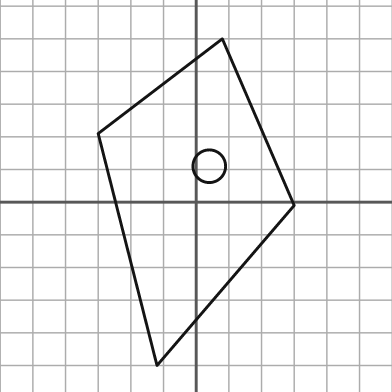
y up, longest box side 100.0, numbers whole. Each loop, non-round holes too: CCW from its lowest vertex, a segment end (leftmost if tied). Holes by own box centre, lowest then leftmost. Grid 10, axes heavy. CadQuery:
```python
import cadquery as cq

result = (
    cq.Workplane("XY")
    .moveTo(-12.0, -50.0)
    .lineTo(30.0, -1.0)
    .lineTo(8.0, 50.0)
    .lineTo(-30.0, 21.0)
    .close()
    .moveTo(4.0, 11.0)
    .circle(5.0)
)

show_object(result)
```